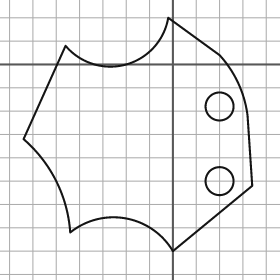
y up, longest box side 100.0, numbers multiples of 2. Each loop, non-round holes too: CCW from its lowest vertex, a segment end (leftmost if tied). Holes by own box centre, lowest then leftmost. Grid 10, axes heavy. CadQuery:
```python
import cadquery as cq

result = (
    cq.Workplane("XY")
    .moveTo(0.0, -80.0)
    .lineTo(34.0, -52.0)
    .lineTo(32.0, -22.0)
    .threePointArc((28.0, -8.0), (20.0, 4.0))
    .lineTo(-2.0, 20.0)
    .threePointArc((-20.0, 0.0), (-46.0, 8.0))
    .lineTo(-64.0, -32.0)
    .threePointArc((-50.0, -50.0), (-44.0, -72.0))
    .threePointArc((-20.0, -66.0), (0.0, -80.0))
    .close()
    .moveTo(20.0, -50.0)
    .circle(6.0)
    .moveTo(20.0, -18.0)
    .circle(6.0)
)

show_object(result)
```